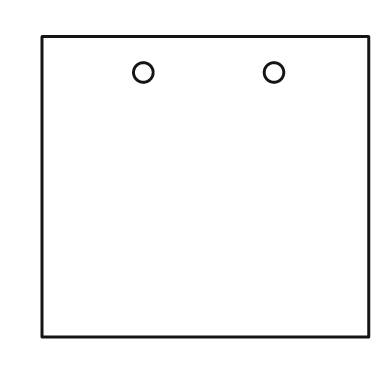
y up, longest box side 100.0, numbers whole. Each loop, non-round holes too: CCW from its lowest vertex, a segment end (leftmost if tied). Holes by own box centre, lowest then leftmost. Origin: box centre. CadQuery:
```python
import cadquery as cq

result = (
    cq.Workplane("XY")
    .moveTo(-50.0, -46.0)
    .lineTo(50.0, -46.0)
    .lineTo(50.0, 46.0)
    .lineTo(-50.0, 46.0)
    .close()
    .moveTo(-19.0, 35.0)
    .circle(3.0)
    .moveTo(21.0, 35.0)
    .circle(3.0)
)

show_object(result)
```